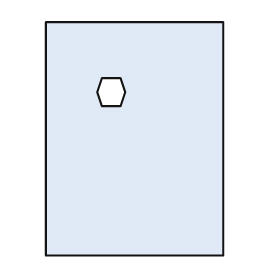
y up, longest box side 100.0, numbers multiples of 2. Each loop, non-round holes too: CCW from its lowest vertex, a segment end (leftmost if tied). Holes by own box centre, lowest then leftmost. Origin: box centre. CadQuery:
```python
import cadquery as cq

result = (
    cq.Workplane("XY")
    .moveTo(-38.0, -50.0)
    .lineTo(38.0, -50.0)
    .lineTo(38.0, 50.0)
    .lineTo(-38.0, 50.0)
    .close()
    .moveTo(-14.0, 14.0)
    .lineTo(-6.0, 14.0)
    .lineTo(-4.0, 20.0)
    .lineTo(-6.0, 26.0)
    .lineTo(-14.0, 26.0)
    .lineTo(-16.0, 20.0)
    .close()
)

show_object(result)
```